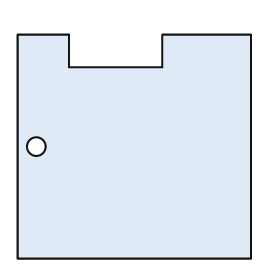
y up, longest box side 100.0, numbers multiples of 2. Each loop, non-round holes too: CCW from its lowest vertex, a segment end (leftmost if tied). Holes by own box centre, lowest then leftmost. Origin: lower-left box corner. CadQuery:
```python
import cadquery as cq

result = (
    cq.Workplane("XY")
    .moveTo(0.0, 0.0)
    .lineTo(100.0, 0.0)
    .lineTo(100.0, 96.0)
    .lineTo(62.0, 96.0)
    .lineTo(62.0, 82.0)
    .lineTo(22.0, 82.0)
    .lineTo(22.0, 96.0)
    .lineTo(0.0, 96.0)
    .close()
    .moveTo(8.0, 48.0)
    .circle(4.0)
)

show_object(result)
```